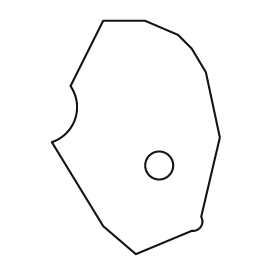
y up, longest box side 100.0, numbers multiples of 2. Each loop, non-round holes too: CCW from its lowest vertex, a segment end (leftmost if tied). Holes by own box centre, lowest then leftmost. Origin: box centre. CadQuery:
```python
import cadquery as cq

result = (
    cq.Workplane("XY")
    .moveTo(0.0, -50.0)
    .lineTo(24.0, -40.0)
    .threePointArc((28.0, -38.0), (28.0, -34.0))
    .lineTo(36.0, 0.0)
    .lineTo(30.0, 28.0)
    .lineTo(24.0, 38.0)
    .lineTo(18.0, 44.0)
    .lineTo(4.0, 50.0)
    .lineTo(-14.0, 50.0)
    .lineTo(-28.0, 22.0)
    .threePointArc((-26.0, 8.0), (-36.0, -2.0))
    .lineTo(-14.0, -38.0)
    .close()
    .moveTo(10.0, -12.0)
    .circle(6.0)
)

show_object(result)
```